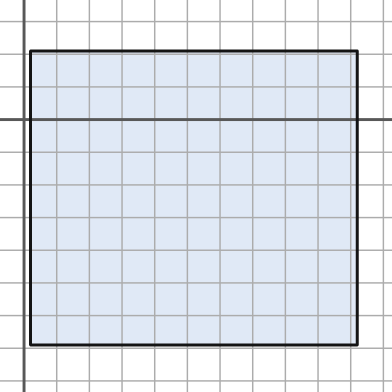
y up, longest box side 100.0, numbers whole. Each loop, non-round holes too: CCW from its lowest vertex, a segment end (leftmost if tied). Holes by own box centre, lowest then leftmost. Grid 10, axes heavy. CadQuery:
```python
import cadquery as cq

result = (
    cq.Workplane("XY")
    .moveTo(2.0, -69.0)
    .lineTo(102.0, -69.0)
    .lineTo(102.0, 21.0)
    .lineTo(2.0, 21.0)
    .close()
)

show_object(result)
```